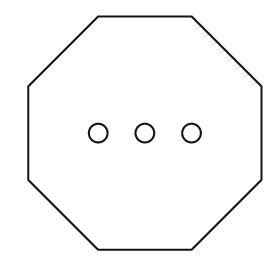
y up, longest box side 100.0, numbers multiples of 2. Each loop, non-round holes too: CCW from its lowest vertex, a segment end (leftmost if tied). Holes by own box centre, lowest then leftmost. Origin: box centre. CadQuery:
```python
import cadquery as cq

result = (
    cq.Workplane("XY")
    .moveTo(-20.0, -50.0)
    .lineTo(20.0, -50.0)
    .lineTo(50.0, -20.0)
    .lineTo(50.0, 20.0)
    .lineTo(20.0, 50.0)
    .lineTo(-20.0, 50.0)
    .lineTo(-50.0, 20.0)
    .lineTo(-50.0, -20.0)
    .close()
    .moveTo(-20.0, 0.0)
    .circle(4.0)
    .moveTo(0.0, 0.0)
    .circle(4.0)
    .moveTo(20.0, 0.0)
    .circle(4.0)
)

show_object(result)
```